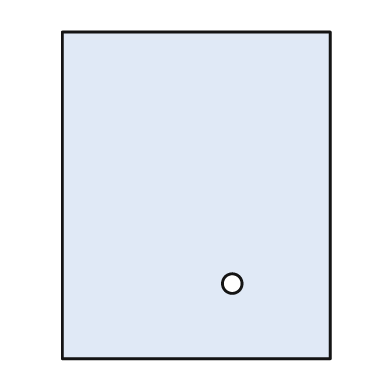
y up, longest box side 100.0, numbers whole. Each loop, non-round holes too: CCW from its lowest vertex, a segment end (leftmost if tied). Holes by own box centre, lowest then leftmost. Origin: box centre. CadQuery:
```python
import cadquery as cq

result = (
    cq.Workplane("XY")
    .moveTo(-41.0, -50.0)
    .lineTo(41.0, -50.0)
    .lineTo(41.0, 50.0)
    .lineTo(-41.0, 50.0)
    .close()
    .moveTo(11.0, -27.0)
    .circle(3.0)
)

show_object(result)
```